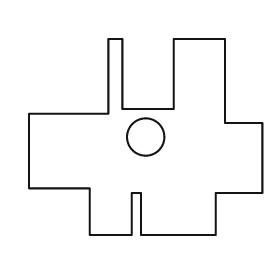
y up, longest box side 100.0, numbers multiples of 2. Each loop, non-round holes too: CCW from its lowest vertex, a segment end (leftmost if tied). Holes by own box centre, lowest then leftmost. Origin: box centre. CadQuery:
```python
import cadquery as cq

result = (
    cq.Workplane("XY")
    .moveTo(-24.0, -42.0)
    .lineTo(-6.0, -42.0)
    .lineTo(-6.0, -24.0)
    .lineTo(-2.0, -24.0)
    .lineTo(-2.0, -42.0)
    .lineTo(30.0, -42.0)
    .lineTo(30.0, -24.0)
    .lineTo(50.0, -24.0)
    .lineTo(50.0, 6.0)
    .lineTo(34.0, 6.0)
    .lineTo(34.0, 42.0)
    .lineTo(12.0, 42.0)
    .lineTo(12.0, 12.0)
    .lineTo(-10.0, 12.0)
    .lineTo(-10.0, 42.0)
    .lineTo(-16.0, 42.0)
    .lineTo(-16.0, 10.0)
    .lineTo(-50.0, 10.0)
    .lineTo(-50.0, -22.0)
    .lineTo(-24.0, -22.0)
    .close()
    .moveTo(0.0, 0.0)
    .circle(8.0)
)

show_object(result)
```